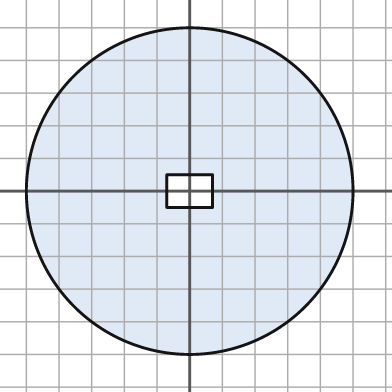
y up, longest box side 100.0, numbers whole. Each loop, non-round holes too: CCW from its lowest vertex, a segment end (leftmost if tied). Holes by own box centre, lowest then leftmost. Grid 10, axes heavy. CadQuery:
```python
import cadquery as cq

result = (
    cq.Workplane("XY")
    .moveTo(0.0, 0.0)
    .circle(50.0)
    .moveTo(-7.0, -5.0)
    .lineTo(7.0, -5.0)
    .lineTo(7.0, 5.0)
    .lineTo(-7.0, 5.0)
    .close()
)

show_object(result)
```